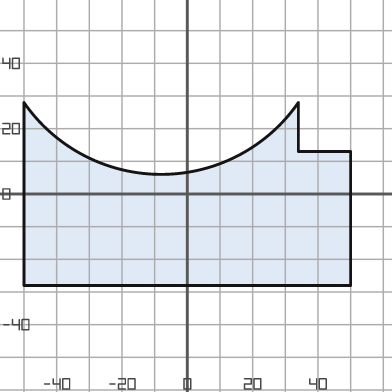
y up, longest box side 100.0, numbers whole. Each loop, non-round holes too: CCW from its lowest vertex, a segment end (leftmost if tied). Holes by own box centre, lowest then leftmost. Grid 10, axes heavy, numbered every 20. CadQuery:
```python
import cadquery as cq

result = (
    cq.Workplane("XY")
    .moveTo(-50.0, -28.0)
    .lineTo(50.0, -28.0)
    .lineTo(50.0, 13.0)
    .lineTo(34.0, 13.0)
    .lineTo(34.0, 28.0)
    .threePointArc((-8.0, 6.0), (-50.0, 28.0))
    .close()
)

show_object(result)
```